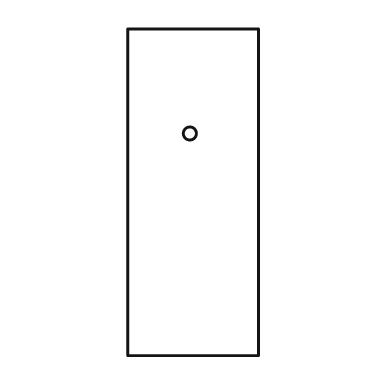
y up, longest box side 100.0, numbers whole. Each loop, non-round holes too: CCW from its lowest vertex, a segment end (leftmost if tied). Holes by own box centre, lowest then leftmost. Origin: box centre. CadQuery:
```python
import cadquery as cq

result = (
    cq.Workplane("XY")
    .moveTo(-20.0, -50.0)
    .lineTo(20.0, -50.0)
    .lineTo(20.0, 50.0)
    .lineTo(-20.0, 50.0)
    .close()
    .moveTo(-1.0, 18.0)
    .circle(2.0)
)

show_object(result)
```